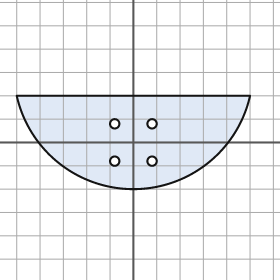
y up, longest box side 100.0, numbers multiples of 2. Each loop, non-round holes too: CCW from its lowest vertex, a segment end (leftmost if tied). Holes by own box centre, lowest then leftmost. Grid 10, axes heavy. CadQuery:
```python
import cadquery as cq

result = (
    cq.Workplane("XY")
    .moveTo(-50.0, 20.0)
    .threePointArc((0.0, -20.0), (50.0, 20.0))
    .close()
    .moveTo(-8.0, -8.0)
    .circle(2.0)
    .moveTo(8.0, -8.0)
    .circle(2.0)
    .moveTo(-8.0, 8.0)
    .circle(2.0)
    .moveTo(8.0, 8.0)
    .circle(2.0)
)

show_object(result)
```